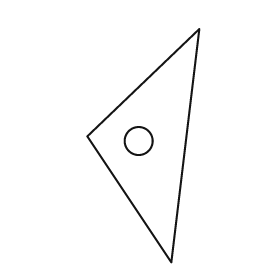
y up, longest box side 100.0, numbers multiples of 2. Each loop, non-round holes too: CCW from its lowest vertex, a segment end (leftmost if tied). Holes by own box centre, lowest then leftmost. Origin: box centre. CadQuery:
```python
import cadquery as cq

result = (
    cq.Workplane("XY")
    .moveTo(12.0, -50.0)
    .lineTo(24.0, 50.0)
    .lineTo(-24.0, 4.0)
    .close()
    .moveTo(-2.0, 2.0)
    .circle(6.0)
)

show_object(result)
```